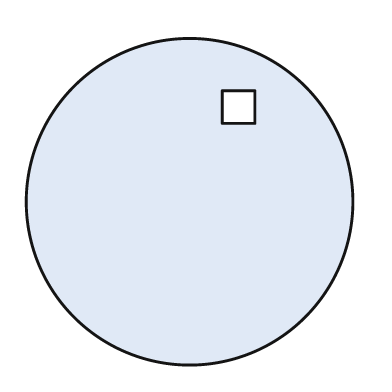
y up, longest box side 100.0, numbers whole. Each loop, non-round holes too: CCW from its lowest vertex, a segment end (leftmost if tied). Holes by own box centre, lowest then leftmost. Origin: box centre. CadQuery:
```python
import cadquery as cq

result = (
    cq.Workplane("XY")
    .moveTo(0.0, 0.0)
    .circle(50.0)
    .moveTo(10.0, 24.0)
    .lineTo(20.0, 24.0)
    .lineTo(20.0, 34.0)
    .lineTo(10.0, 34.0)
    .close()
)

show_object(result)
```